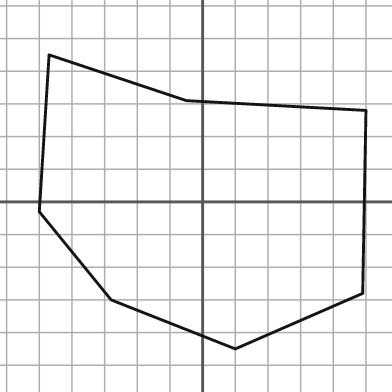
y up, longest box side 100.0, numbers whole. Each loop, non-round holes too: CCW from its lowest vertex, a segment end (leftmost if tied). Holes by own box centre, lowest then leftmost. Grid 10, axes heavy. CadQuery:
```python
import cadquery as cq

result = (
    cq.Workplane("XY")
    .moveTo(10.0, -45.0)
    .lineTo(49.0, -28.0)
    .lineTo(50.0, 28.0)
    .lineTo(-5.0, 31.0)
    .lineTo(-47.0, 45.0)
    .lineTo(-50.0, -3.0)
    .lineTo(-28.0, -30.0)
    .close()
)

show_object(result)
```